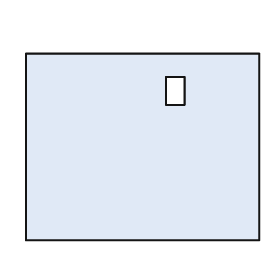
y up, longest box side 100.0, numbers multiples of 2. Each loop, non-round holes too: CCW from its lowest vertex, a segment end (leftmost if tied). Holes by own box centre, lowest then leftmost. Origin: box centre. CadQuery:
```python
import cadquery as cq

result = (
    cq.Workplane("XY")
    .moveTo(-50.0, -40.0)
    .lineTo(50.0, -40.0)
    .lineTo(50.0, 40.0)
    .lineTo(-50.0, 40.0)
    .close()
    .moveTo(10.0, 18.0)
    .lineTo(18.0, 18.0)
    .lineTo(18.0, 30.0)
    .lineTo(10.0, 30.0)
    .close()
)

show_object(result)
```